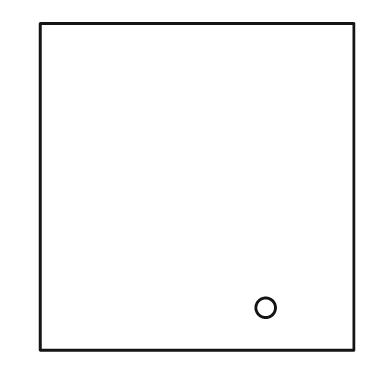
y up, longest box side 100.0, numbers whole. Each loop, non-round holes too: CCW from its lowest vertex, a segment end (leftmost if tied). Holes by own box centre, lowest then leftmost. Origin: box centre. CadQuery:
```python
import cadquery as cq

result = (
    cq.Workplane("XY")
    .moveTo(-48.0, -50.0)
    .lineTo(48.0, -50.0)
    .lineTo(48.0, 50.0)
    .lineTo(-48.0, 50.0)
    .close()
    .moveTo(21.0, -37.0)
    .circle(3.0)
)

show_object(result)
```